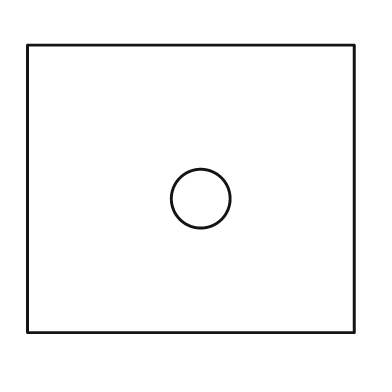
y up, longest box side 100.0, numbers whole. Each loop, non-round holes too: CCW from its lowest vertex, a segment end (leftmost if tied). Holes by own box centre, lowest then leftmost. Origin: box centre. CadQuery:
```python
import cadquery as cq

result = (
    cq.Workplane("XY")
    .moveTo(-50.0, -44.0)
    .lineTo(50.0, -44.0)
    .lineTo(50.0, 44.0)
    .lineTo(-50.0, 44.0)
    .close()
    .moveTo(3.0, -3.0)
    .circle(9.0)
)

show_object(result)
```